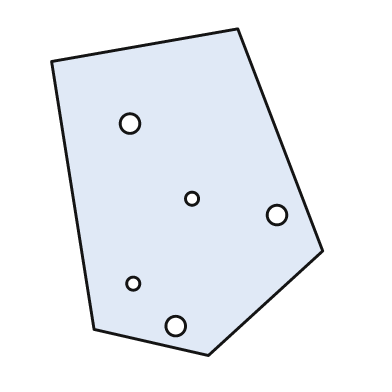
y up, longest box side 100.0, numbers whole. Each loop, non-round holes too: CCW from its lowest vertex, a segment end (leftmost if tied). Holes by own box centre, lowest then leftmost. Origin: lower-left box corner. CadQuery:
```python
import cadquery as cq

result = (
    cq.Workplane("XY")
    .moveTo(48.0, 0.0)
    .lineTo(83.0, 32.0)
    .lineTo(57.0, 100.0)
    .lineTo(0.0, 90.0)
    .lineTo(13.0, 8.0)
    .close()
    .moveTo(38.0, 9.0)
    .circle(3.0)
    .moveTo(25.0, 22.0)
    .circle(2.0)
    .moveTo(69.0, 43.0)
    .circle(3.0)
    .moveTo(43.0, 48.0)
    .circle(2.0)
    .moveTo(24.0, 71.0)
    .circle(3.0)
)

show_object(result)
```